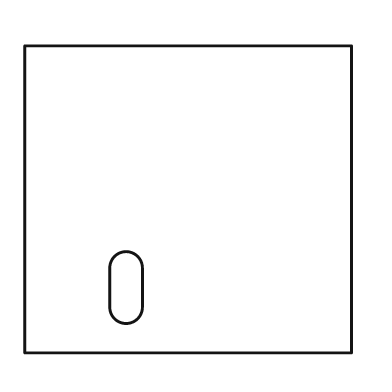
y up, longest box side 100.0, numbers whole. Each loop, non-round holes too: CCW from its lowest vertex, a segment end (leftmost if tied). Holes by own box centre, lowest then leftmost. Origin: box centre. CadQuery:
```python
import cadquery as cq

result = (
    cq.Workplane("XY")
    .moveTo(-50.0, -47.0)
    .lineTo(50.0, -47.0)
    .lineTo(50.0, 47.0)
    .lineTo(-50.0, 47.0)
    .close()
    .moveTo(-24.0, -33.0)
    .threePointArc((-19.0, -38.0), (-14.0, -33.0))
    .lineTo(-14.0, -21.0)
    .threePointArc((-19.0, -16.0), (-24.0, -21.0))
    .close()
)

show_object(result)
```